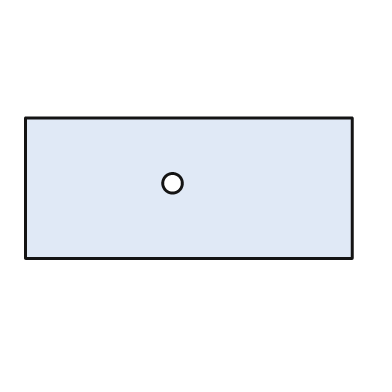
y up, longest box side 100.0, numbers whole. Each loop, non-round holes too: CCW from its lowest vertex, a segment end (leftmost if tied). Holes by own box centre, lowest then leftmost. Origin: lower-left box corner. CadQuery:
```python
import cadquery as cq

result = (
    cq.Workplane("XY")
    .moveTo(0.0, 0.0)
    .lineTo(100.0, 0.0)
    .lineTo(100.0, 43.0)
    .lineTo(0.0, 43.0)
    .close()
    .moveTo(45.0, 23.0)
    .circle(3.0)
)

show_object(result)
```